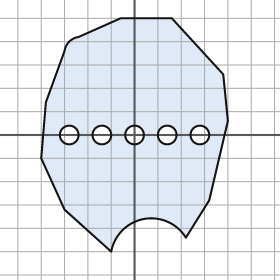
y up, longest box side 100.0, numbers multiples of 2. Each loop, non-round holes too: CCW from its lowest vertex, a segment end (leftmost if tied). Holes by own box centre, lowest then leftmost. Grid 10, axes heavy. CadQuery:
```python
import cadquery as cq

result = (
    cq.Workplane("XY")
    .moveTo(-10.0, -50.0)
    .threePointArc((4.0, -36.0), (22.0, -44.0))
    .lineTo(32.0, -28.0)
    .lineTo(40.0, 6.0)
    .lineTo(38.0, 26.0)
    .lineTo(16.0, 50.0)
    .lineTo(-6.0, 50.0)
    .lineTo(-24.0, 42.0)
    .threePointArc((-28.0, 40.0), (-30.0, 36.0))
    .lineTo(-38.0, 14.0)
    .lineTo(-40.0, -10.0)
    .lineTo(-30.0, -32.0)
    .close()
    .moveTo(-28.0, 0.0)
    .circle(4.0)
    .moveTo(-14.0, 0.0)
    .circle(4.0)
    .moveTo(0.0, 0.0)
    .circle(4.0)
    .moveTo(14.0, 0.0)
    .circle(4.0)
    .moveTo(28.0, 0.0)
    .circle(4.0)
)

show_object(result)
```